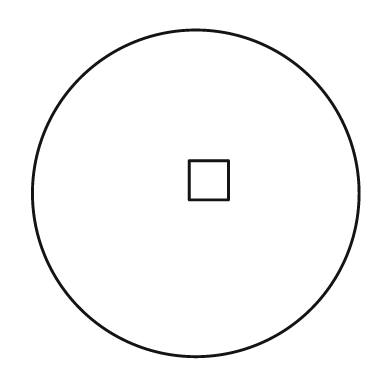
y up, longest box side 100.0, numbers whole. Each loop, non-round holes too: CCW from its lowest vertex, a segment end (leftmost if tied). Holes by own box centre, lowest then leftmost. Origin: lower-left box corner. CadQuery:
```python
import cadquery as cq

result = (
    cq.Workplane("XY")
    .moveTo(50.0, 50.0)
    .circle(50.0)
    .moveTo(48.0, 48.0)
    .lineTo(60.0, 48.0)
    .lineTo(60.0, 60.0)
    .lineTo(48.0, 60.0)
    .close()
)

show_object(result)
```